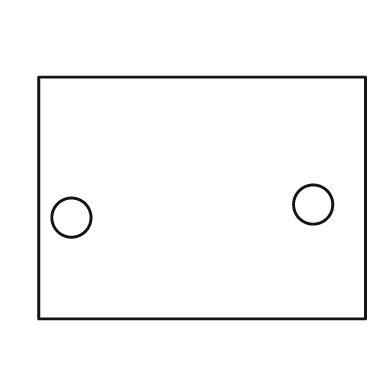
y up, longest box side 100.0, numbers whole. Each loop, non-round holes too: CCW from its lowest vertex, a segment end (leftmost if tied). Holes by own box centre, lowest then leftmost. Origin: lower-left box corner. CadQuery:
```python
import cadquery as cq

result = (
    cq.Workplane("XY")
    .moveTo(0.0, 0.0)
    .lineTo(100.0, 0.0)
    .lineTo(100.0, 74.0)
    .lineTo(0.0, 74.0)
    .close()
    .moveTo(10.0, 31.0)
    .circle(6.0)
    .moveTo(84.0, 35.0)
    .circle(6.0)
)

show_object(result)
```